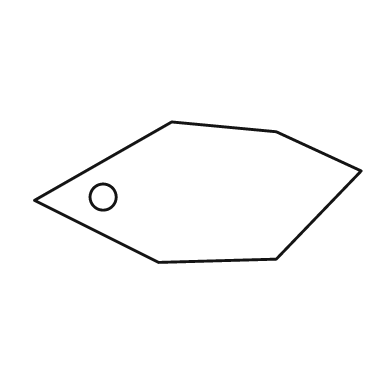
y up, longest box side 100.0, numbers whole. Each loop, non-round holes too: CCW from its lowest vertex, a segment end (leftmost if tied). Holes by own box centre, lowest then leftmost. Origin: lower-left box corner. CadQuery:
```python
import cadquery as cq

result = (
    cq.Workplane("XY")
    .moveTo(38.0, 0.0)
    .lineTo(74.0, 1.0)
    .lineTo(100.0, 28.0)
    .lineTo(74.0, 40.0)
    .lineTo(42.0, 43.0)
    .lineTo(0.0, 19.0)
    .close()
    .moveTo(21.0, 20.0)
    .circle(4.0)
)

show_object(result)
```